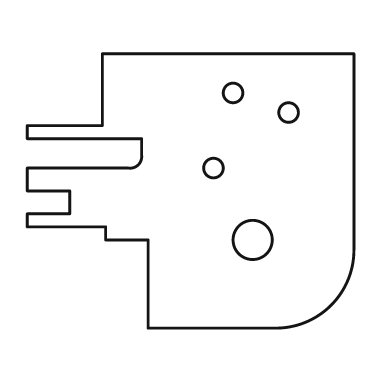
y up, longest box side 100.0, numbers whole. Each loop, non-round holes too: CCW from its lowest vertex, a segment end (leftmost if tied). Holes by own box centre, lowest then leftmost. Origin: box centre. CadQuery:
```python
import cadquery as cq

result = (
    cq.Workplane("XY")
    .moveTo(-13.0, -42.0)
    .lineTo(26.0, -42.0)
    .threePointArc((43.0, -35.0), (50.0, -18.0))
    .lineTo(50.0, 42.0)
    .lineTo(-27.0, 42.0)
    .lineTo(-27.0, 20.0)
    .lineTo(-50.0, 20.0)
    .lineTo(-50.0, 16.0)
    .lineTo(-15.0, 16.0)
    .lineTo(-15.0, 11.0)
    .threePointArc((-16.0, 8.0), (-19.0, 7.0))
    .lineTo(-50.0, 7.0)
    .lineTo(-50.0, 0.0)
    .lineTo(-37.0, 0.0)
    .lineTo(-37.0, -7.0)
    .lineTo(-50.0, -7.0)
    .lineTo(-50.0, -11.0)
    .lineTo(-26.0, -11.0)
    .lineTo(-26.0, -15.0)
    .lineTo(-13.0, -15.0)
    .close()
    .moveTo(19.0, -15.0)
    .circle(6.0)
    .moveTo(7.0, 7.0)
    .circle(3.0)
    .moveTo(30.0, 24.0)
    .circle(3.0)
    .moveTo(13.0, 30.0)
    .circle(3.0)
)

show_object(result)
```